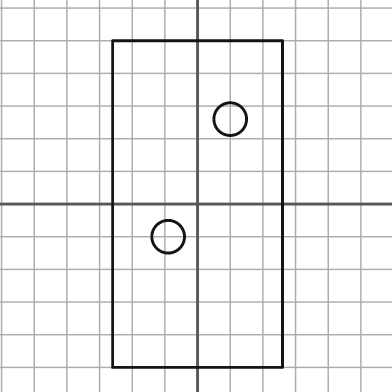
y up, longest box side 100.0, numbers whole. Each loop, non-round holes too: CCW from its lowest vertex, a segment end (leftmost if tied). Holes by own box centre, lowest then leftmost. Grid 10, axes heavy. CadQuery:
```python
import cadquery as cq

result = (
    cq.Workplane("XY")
    .moveTo(-26.0, -50.0)
    .lineTo(26.0, -50.0)
    .lineTo(26.0, 50.0)
    .lineTo(-26.0, 50.0)
    .close()
    .moveTo(-9.0, -10.0)
    .circle(5.0)
    .moveTo(10.0, 26.0)
    .circle(5.0)
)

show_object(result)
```